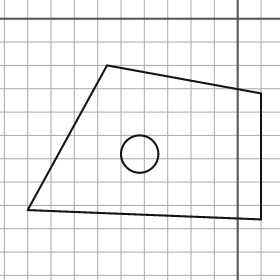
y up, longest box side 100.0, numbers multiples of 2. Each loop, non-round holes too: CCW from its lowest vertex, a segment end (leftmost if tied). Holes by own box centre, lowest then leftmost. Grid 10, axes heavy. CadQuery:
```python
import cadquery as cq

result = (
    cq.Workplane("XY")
    .moveTo(10.0, -86.0)
    .lineTo(10.0, -32.0)
    .lineTo(-56.0, -20.0)
    .lineTo(-90.0, -82.0)
    .close()
    .moveTo(-42.0, -58.0)
    .circle(8.0)
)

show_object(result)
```